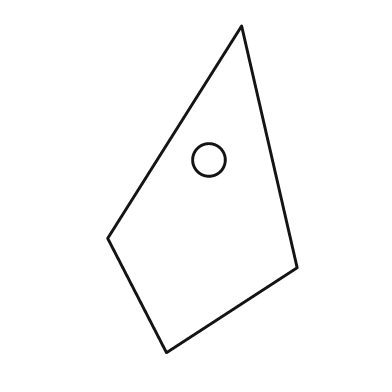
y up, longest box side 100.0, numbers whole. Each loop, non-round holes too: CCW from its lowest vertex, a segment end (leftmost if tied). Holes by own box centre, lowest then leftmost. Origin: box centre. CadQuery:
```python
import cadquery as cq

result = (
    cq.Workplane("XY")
    .moveTo(-11.0, -50.0)
    .lineTo(29.0, -24.0)
    .lineTo(12.0, 50.0)
    .lineTo(-29.0, -15.0)
    .close()
    .moveTo(2.0, 9.0)
    .circle(5.0)
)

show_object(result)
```